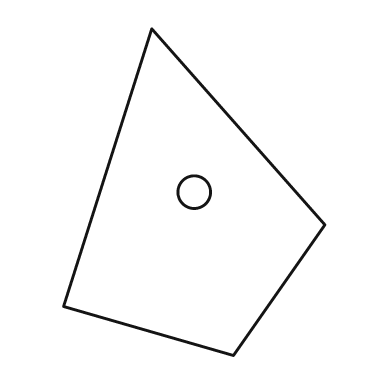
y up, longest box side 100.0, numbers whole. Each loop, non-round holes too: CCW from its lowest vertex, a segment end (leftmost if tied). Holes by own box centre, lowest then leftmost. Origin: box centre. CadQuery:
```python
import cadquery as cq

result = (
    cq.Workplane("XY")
    .moveTo(12.0, -50.0)
    .lineTo(40.0, -10.0)
    .lineTo(-13.0, 50.0)
    .lineTo(-40.0, -35.0)
    .close()
    .moveTo(0.0, 0.0)
    .circle(5.0)
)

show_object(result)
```